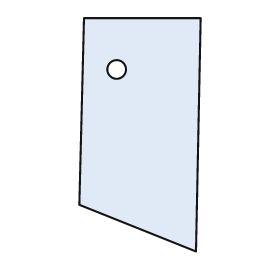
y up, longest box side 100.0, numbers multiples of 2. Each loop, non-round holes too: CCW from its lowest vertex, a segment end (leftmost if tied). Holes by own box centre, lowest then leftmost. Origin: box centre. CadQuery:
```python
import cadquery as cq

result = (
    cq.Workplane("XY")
    .moveTo(24.0, -50.0)
    .lineTo(26.0, 50.0)
    .lineTo(-24.0, 50.0)
    .lineTo(-26.0, -30.0)
    .close()
    .moveTo(-10.0, 28.0)
    .circle(4.0)
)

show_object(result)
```